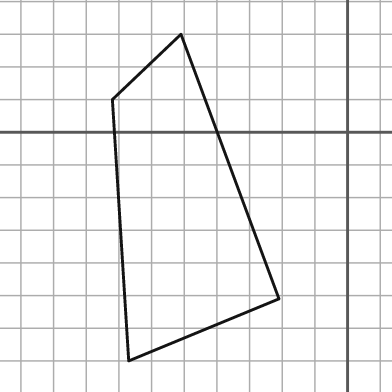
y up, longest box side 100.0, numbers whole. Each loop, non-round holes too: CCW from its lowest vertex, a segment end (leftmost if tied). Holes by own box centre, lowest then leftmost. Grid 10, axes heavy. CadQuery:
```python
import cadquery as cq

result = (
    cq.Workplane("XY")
    .moveTo(-67.0, -70.0)
    .lineTo(-21.0, -51.0)
    .lineTo(-51.0, 30.0)
    .lineTo(-72.0, 10.0)
    .close()
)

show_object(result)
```